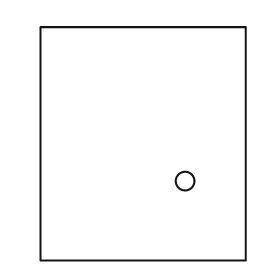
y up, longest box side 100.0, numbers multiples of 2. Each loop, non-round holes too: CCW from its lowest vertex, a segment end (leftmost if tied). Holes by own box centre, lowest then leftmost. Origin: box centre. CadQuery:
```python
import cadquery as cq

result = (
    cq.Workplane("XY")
    .moveTo(-44.0, -50.0)
    .lineTo(44.0, -50.0)
    .lineTo(44.0, 50.0)
    .lineTo(-44.0, 50.0)
    .close()
    .moveTo(18.0, -16.0)
    .circle(4.0)
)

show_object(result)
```